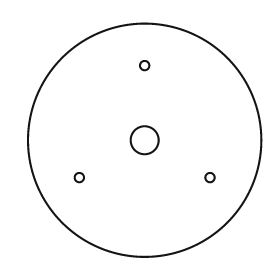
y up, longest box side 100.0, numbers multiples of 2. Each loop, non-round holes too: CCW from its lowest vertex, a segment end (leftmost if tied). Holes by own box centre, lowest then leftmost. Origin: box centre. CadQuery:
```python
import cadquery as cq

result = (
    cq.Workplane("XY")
    .moveTo(0.0, 0.0)
    .circle(50.0)
    .moveTo(-28.0, -16.0)
    .circle(2.0)
    .moveTo(28.0, -16.0)
    .circle(2.0)
    .moveTo(0.0, 0.0)
    .circle(6.0)
    .moveTo(0.0, 32.0)
    .circle(2.0)
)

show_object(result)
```